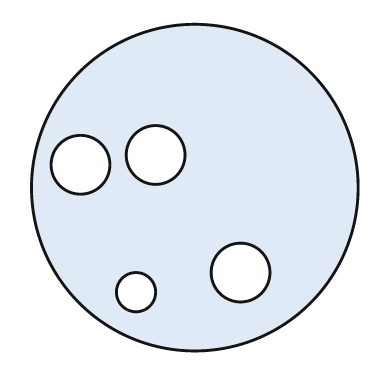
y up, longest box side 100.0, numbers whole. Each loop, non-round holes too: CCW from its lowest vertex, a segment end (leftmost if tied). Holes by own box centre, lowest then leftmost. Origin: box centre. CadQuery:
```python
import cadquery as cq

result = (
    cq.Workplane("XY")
    .moveTo(0.0, 0.0)
    .circle(50.0)
    .moveTo(-18.0, -32.0)
    .circle(6.0)
    .moveTo(14.0, -26.0)
    .circle(9.0)
    .moveTo(-35.0, 7.0)
    .circle(9.0)
    .moveTo(-12.0, 10.0)
    .circle(9.0)
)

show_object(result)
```